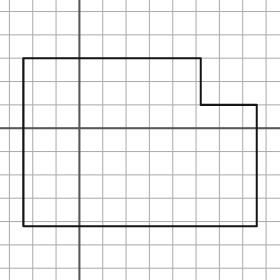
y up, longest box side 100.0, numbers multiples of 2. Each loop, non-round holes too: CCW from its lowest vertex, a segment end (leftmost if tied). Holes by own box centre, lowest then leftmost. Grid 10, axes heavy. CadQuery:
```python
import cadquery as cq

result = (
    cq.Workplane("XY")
    .moveTo(-24.0, -42.0)
    .lineTo(76.0, -42.0)
    .lineTo(76.0, 10.0)
    .lineTo(52.0, 10.0)
    .lineTo(52.0, 30.0)
    .lineTo(-24.0, 30.0)
    .close()
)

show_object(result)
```